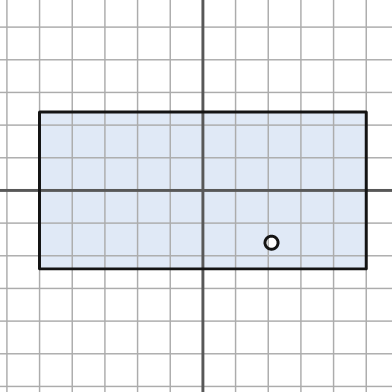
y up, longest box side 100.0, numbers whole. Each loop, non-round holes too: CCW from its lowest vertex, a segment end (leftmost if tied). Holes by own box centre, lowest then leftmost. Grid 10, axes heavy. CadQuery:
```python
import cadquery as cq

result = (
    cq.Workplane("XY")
    .moveTo(-50.0, -24.0)
    .lineTo(50.0, -24.0)
    .lineTo(50.0, 24.0)
    .lineTo(-50.0, 24.0)
    .close()
    .moveTo(21.0, -16.0)
    .circle(2.0)
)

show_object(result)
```